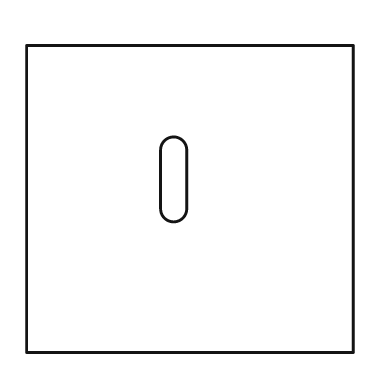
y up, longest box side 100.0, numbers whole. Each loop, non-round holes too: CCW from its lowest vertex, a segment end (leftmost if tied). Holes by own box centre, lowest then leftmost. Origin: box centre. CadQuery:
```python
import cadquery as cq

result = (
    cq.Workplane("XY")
    .moveTo(-50.0, -47.0)
    .lineTo(50.0, -47.0)
    .lineTo(50.0, 47.0)
    .lineTo(-50.0, 47.0)
    .close()
    .moveTo(-9.0, -3.0)
    .threePointArc((-5.0, -7.0), (-1.0, -3.0))
    .lineTo(-1.0, 15.0)
    .threePointArc((-5.0, 19.0), (-9.0, 15.0))
    .close()
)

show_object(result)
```